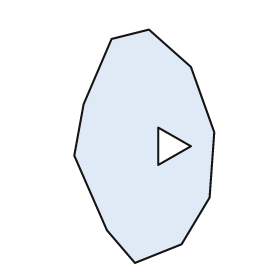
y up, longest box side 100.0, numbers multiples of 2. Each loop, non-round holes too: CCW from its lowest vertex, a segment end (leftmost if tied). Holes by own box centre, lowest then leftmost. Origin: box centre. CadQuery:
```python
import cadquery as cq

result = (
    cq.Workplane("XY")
    .moveTo(-4.0, -50.0)
    .lineTo(16.0, -42.0)
    .lineTo(28.0, -22.0)
    .lineTo(30.0, 6.0)
    .lineTo(20.0, 34.0)
    .lineTo(2.0, 50.0)
    .lineTo(-14.0, 46.0)
    .lineTo(-26.0, 18.0)
    .lineTo(-30.0, -4.0)
    .lineTo(-16.0, -36.0)
    .close()
    .moveTo(6.0, -8.0)
    .lineTo(20.0, 0.0)
    .lineTo(6.0, 8.0)
    .close()
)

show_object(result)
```